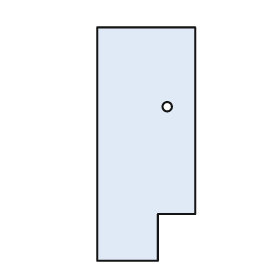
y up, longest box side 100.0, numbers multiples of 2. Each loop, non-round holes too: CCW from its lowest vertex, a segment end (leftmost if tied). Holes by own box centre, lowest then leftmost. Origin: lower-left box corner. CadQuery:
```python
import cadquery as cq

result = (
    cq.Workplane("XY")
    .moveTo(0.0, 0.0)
    .lineTo(26.0, 0.0)
    .lineTo(26.0, 20.0)
    .lineTo(42.0, 20.0)
    .lineTo(42.0, 100.0)
    .lineTo(0.0, 100.0)
    .close()
    .moveTo(30.0, 66.0)
    .circle(2.0)
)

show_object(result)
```